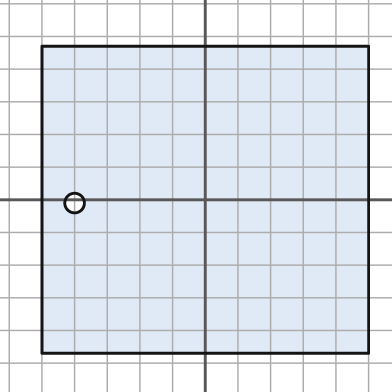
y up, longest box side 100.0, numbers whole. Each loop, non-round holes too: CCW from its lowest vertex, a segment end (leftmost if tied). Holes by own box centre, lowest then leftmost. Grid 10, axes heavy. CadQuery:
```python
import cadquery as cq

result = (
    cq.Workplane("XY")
    .moveTo(-50.0, -47.0)
    .lineTo(50.0, -47.0)
    .lineTo(50.0, 47.0)
    .lineTo(-50.0, 47.0)
    .close()
    .moveTo(-40.0, -1.0)
    .circle(3.0)
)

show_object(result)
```